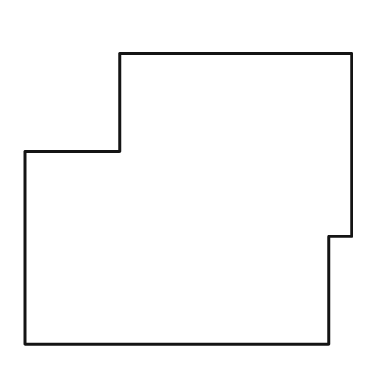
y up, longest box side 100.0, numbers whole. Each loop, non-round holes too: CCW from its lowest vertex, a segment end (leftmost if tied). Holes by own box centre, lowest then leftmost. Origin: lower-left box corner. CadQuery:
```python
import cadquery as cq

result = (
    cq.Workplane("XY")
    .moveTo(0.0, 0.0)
    .lineTo(93.0, 0.0)
    .lineTo(93.0, 33.0)
    .lineTo(100.0, 33.0)
    .lineTo(100.0, 89.0)
    .lineTo(29.0, 89.0)
    .lineTo(29.0, 59.0)
    .lineTo(0.0, 59.0)
    .close()
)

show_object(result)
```